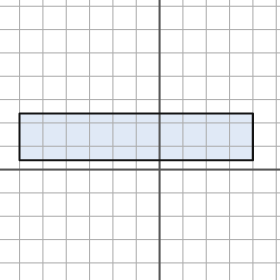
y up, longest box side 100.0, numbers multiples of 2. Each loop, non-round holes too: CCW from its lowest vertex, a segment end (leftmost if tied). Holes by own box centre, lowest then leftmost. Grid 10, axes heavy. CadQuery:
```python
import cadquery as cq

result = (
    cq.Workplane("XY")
    .moveTo(-60.0, 4.0)
    .lineTo(40.0, 4.0)
    .lineTo(40.0, 24.0)
    .lineTo(-60.0, 24.0)
    .close()
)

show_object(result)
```